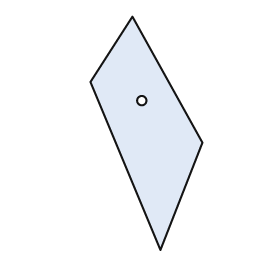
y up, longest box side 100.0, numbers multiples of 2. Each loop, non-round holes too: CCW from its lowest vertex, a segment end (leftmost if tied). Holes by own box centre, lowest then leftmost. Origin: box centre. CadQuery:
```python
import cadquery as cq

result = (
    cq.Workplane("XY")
    .moveTo(6.0, -50.0)
    .lineTo(24.0, -4.0)
    .lineTo(-6.0, 50.0)
    .lineTo(-24.0, 22.0)
    .close()
    .moveTo(-2.0, 14.0)
    .circle(2.0)
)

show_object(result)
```